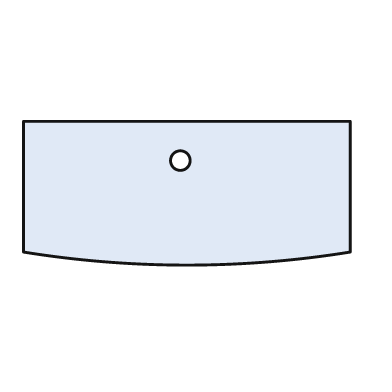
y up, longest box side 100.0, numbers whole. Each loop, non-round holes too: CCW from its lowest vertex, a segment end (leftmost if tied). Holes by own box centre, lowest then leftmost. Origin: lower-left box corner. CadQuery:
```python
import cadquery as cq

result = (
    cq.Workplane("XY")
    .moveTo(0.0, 4.0)
    .threePointArc((50.0, 0.0), (100.0, 4.0))
    .lineTo(100.0, 44.0)
    .lineTo(0.0, 44.0)
    .close()
    .moveTo(48.0, 32.0)
    .circle(3.0)
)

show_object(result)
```